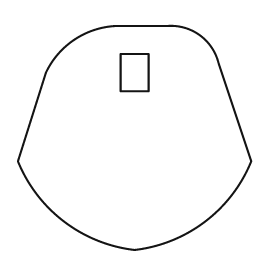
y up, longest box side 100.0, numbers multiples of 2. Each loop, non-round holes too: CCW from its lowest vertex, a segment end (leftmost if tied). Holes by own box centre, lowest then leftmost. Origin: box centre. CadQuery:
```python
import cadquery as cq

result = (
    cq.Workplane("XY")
    .moveTo(0.0, -48.0)
    .threePointArc((30.0, -36.0), (50.0, -10.0))
    .lineTo(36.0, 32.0)
    .threePointArc((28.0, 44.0), (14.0, 48.0))
    .lineTo(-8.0, 48.0)
    .threePointArc((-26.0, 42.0), (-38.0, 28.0))
    .lineTo(-50.0, -10.0)
    .threePointArc((-30.0, -36.0), (0.0, -48.0))
    .close()
    .moveTo(-6.0, 20.0)
    .lineTo(6.0, 20.0)
    .lineTo(6.0, 36.0)
    .lineTo(-6.0, 36.0)
    .close()
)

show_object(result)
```